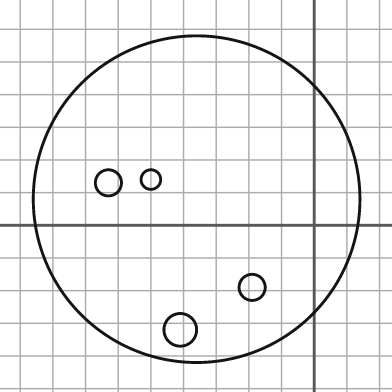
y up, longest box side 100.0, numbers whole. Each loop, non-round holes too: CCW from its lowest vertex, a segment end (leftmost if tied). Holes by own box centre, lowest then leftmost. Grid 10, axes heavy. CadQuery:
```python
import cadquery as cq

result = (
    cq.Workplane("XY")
    .moveTo(-36.0, 8.0)
    .circle(50.0)
    .moveTo(-41.0, -32.0)
    .circle(5.0)
    .moveTo(-19.0, -19.0)
    .circle(4.0)
    .moveTo(-63.0, 13.0)
    .circle(4.0)
    .moveTo(-50.0, 14.0)
    .circle(3.0)
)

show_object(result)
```